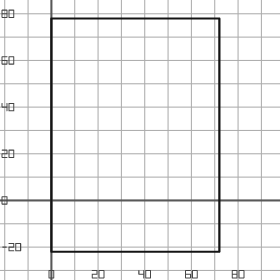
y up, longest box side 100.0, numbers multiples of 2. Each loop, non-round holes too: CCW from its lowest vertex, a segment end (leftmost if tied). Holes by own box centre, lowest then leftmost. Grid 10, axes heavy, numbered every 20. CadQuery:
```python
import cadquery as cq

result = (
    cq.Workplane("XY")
    .moveTo(0.0, -22.0)
    .lineTo(72.0, -22.0)
    .lineTo(72.0, 78.0)
    .lineTo(0.0, 78.0)
    .close()
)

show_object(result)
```